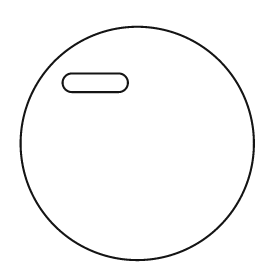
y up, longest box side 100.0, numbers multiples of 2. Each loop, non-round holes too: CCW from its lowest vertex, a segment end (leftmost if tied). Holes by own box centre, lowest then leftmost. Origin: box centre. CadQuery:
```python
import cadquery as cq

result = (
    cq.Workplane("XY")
    .moveTo(0.0, 0.0)
    .circle(50.0)
    .moveTo(-28.0, 22.0)
    .lineTo(-8.0, 22.0)
    .threePointArc((-4.0, 26.0), (-8.0, 30.0))
    .lineTo(-28.0, 30.0)
    .threePointArc((-32.0, 26.0), (-28.0, 22.0))
    .close()
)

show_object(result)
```